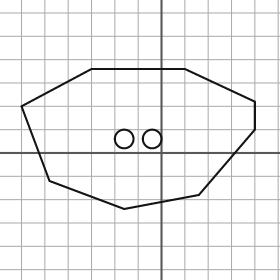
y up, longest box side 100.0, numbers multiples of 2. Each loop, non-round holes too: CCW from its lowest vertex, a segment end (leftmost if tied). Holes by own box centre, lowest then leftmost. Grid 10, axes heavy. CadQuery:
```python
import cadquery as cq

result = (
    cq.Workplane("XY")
    .moveTo(-16.0, -24.0)
    .lineTo(16.0, -18.0)
    .lineTo(40.0, 10.0)
    .lineTo(40.0, 22.0)
    .lineTo(10.0, 36.0)
    .lineTo(-30.0, 36.0)
    .lineTo(-60.0, 20.0)
    .lineTo(-48.0, -12.0)
    .close()
    .moveTo(-16.0, 6.0)
    .circle(4.0)
    .moveTo(-4.0, 6.0)
    .circle(4.0)
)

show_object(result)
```